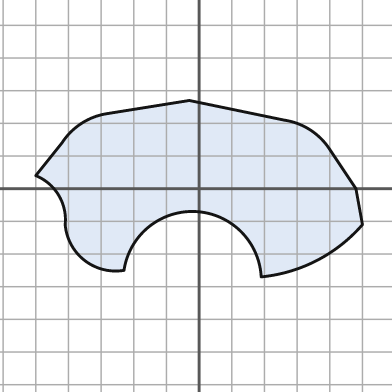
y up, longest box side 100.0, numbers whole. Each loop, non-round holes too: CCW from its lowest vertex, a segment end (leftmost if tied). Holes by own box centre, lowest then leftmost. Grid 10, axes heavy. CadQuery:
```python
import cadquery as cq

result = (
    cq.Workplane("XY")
    .moveTo(19.0, -27.0)
    .threePointArc((36.0, -22.0), (50.0, -11.0))
    .lineTo(48.0, 0.0)
    .lineTo(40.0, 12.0)
    .threePointArc((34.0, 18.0), (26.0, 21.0))
    .lineTo(-3.0, 27.0)
    .lineTo(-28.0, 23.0)
    .threePointArc((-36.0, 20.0), (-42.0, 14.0))
    .lineTo(-50.0, 4.0)
    .threePointArc((-43.0, -2.0), (-41.0, -11.0))
    .threePointArc((-35.0, -22.0), (-23.0, -25.0))
    .threePointArc((-1.0, -7.0), (19.0, -27.0))
    .close()
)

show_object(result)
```